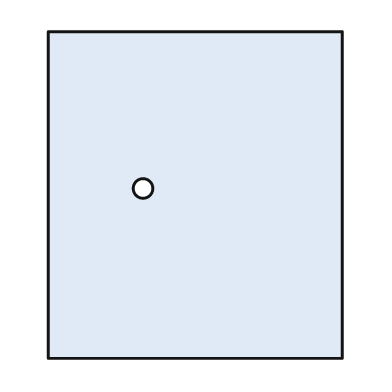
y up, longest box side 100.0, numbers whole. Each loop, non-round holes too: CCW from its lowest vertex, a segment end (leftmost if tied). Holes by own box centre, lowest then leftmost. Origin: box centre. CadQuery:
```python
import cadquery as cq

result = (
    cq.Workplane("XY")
    .moveTo(-45.0, -50.0)
    .lineTo(45.0, -50.0)
    .lineTo(45.0, 50.0)
    .lineTo(-45.0, 50.0)
    .close()
    .moveTo(-16.0, 2.0)
    .circle(3.0)
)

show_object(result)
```